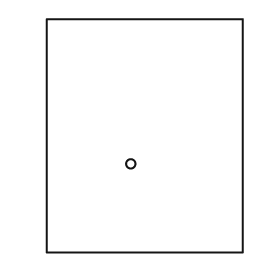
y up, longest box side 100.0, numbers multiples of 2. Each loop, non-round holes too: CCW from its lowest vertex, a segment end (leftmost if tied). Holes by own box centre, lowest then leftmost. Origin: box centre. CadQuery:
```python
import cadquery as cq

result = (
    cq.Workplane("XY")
    .moveTo(-42.0, -50.0)
    .lineTo(42.0, -50.0)
    .lineTo(42.0, 50.0)
    .lineTo(-42.0, 50.0)
    .close()
    .moveTo(-6.0, -12.0)
    .circle(2.0)
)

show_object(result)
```